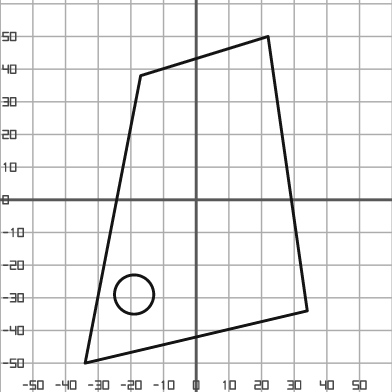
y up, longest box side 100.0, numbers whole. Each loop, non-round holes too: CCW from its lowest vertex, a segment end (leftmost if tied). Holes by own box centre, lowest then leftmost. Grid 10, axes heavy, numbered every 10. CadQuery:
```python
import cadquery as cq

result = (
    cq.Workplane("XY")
    .moveTo(-34.0, -50.0)
    .lineTo(34.0, -34.0)
    .lineTo(22.0, 50.0)
    .lineTo(-17.0, 38.0)
    .close()
    .moveTo(-19.0, -29.0)
    .circle(6.0)
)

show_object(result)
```